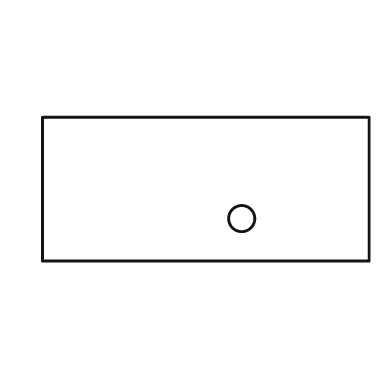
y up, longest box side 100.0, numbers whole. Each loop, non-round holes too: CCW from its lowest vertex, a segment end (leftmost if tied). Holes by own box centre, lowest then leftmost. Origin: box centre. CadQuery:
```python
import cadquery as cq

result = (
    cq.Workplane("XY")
    .moveTo(-50.0, -22.0)
    .lineTo(50.0, -22.0)
    .lineTo(50.0, 22.0)
    .lineTo(-50.0, 22.0)
    .close()
    .moveTo(11.0, -9.0)
    .circle(4.0)
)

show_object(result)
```